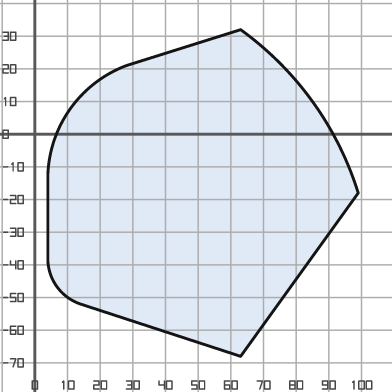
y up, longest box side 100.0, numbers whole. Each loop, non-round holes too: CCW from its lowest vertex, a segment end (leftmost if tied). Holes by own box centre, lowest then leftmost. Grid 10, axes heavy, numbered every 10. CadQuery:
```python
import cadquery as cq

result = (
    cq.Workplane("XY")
    .moveTo(63.0, -68.0)
    .lineTo(99.0, -18.0)
    .threePointArc((85.0, 10.0), (63.0, 32.0))
    .lineTo(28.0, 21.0)
    .threePointArc((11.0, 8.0), (4.0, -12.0))
    .lineTo(4.0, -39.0)
    .threePointArc((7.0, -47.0), (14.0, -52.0))
    .close()
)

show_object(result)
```